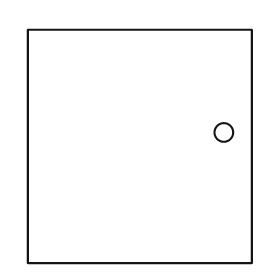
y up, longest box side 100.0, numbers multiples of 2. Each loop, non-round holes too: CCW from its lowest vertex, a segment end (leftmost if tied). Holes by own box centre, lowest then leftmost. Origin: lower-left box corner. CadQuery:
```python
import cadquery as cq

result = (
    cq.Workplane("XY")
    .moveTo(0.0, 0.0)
    .lineTo(96.0, 0.0)
    .lineTo(96.0, 100.0)
    .lineTo(0.0, 100.0)
    .close()
    .moveTo(84.0, 56.0)
    .circle(4.0)
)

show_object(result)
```